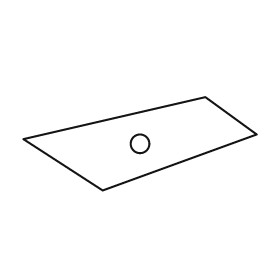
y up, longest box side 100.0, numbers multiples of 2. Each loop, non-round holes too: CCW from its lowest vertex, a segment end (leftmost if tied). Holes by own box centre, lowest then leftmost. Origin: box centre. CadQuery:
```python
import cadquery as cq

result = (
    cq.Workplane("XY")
    .moveTo(-16.0, -20.0)
    .lineTo(50.0, 4.0)
    .lineTo(28.0, 20.0)
    .lineTo(-50.0, 2.0)
    .close()
    .moveTo(0.0, 0.0)
    .circle(4.0)
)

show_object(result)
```